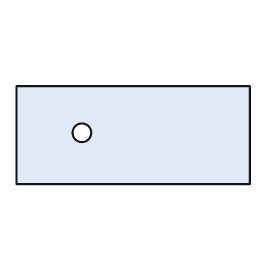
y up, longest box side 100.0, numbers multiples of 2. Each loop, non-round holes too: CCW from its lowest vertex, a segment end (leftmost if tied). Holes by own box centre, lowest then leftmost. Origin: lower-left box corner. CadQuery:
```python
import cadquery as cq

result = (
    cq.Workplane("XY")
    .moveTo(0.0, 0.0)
    .lineTo(100.0, 0.0)
    .lineTo(100.0, 42.0)
    .lineTo(0.0, 42.0)
    .close()
    .moveTo(28.0, 22.0)
    .circle(4.0)
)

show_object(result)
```